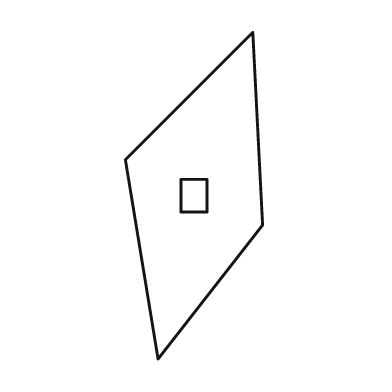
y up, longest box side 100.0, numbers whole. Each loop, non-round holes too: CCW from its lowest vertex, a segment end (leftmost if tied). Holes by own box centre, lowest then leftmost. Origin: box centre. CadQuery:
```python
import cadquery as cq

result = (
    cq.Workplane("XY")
    .moveTo(-11.0, -50.0)
    .lineTo(21.0, -9.0)
    .lineTo(18.0, 50.0)
    .lineTo(-21.0, 11.0)
    .close()
    .moveTo(-4.0, -5.0)
    .lineTo(4.0, -5.0)
    .lineTo(4.0, 5.0)
    .lineTo(-4.0, 5.0)
    .close()
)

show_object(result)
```